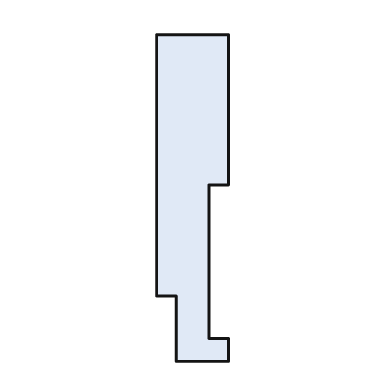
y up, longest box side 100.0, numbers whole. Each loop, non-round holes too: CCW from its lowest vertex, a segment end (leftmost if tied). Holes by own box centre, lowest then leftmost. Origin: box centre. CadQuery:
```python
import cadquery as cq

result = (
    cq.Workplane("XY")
    .moveTo(-5.0, -50.0)
    .lineTo(11.0, -50.0)
    .lineTo(11.0, -43.0)
    .lineTo(5.0, -43.0)
    .lineTo(5.0, 4.0)
    .lineTo(11.0, 4.0)
    .lineTo(11.0, 50.0)
    .lineTo(-11.0, 50.0)
    .lineTo(-11.0, -30.0)
    .lineTo(-5.0, -30.0)
    .close()
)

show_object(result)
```